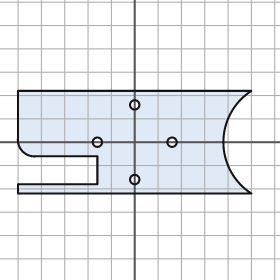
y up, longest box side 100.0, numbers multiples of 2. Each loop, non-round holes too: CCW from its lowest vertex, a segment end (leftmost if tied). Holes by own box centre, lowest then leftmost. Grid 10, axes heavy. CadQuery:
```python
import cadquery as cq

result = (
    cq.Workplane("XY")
    .moveTo(-50.0, -22.0)
    .lineTo(50.0, -22.0)
    .threePointArc((38.0, 0.0), (50.0, 22.0))
    .lineTo(-50.0, 22.0)
    .lineTo(-50.0, 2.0)
    .threePointArc((-48.0, -4.0), (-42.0, -6.0))
    .lineTo(-16.0, -6.0)
    .lineTo(-16.0, -18.0)
    .lineTo(-50.0, -18.0)
    .close()
    .moveTo(0.0, -16.0)
    .circle(2.0)
    .moveTo(-16.0, 0.0)
    .circle(2.0)
    .moveTo(16.0, 0.0)
    .circle(2.0)
    .moveTo(0.0, 16.0)
    .circle(2.0)
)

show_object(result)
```